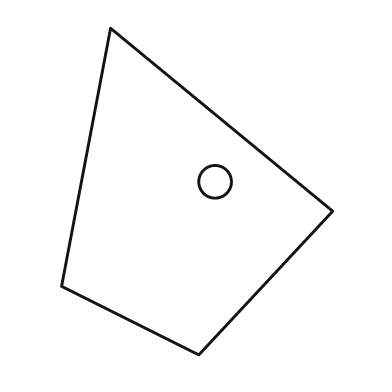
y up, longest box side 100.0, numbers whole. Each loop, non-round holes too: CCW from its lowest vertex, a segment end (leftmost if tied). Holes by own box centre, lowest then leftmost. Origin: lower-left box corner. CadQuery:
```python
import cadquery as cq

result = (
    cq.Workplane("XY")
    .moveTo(42.0, 0.0)
    .lineTo(83.0, 44.0)
    .lineTo(15.0, 100.0)
    .lineTo(0.0, 21.0)
    .close()
    .moveTo(47.0, 53.0)
    .circle(5.0)
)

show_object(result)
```